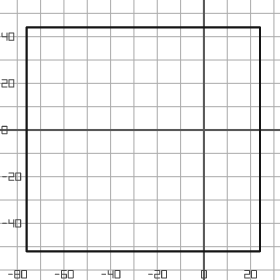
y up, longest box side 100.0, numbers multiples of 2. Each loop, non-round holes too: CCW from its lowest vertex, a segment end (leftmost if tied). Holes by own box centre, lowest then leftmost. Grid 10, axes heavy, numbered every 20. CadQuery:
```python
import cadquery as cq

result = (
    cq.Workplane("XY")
    .moveTo(-76.0, -52.0)
    .lineTo(24.0, -52.0)
    .lineTo(24.0, 44.0)
    .lineTo(-76.0, 44.0)
    .close()
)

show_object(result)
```